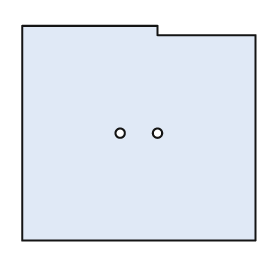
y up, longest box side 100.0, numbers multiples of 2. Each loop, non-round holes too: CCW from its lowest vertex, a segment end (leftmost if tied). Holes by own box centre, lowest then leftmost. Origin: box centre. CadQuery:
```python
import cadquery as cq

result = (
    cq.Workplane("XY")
    .moveTo(-50.0, -46.0)
    .lineTo(50.0, -46.0)
    .lineTo(50.0, 42.0)
    .lineTo(8.0, 42.0)
    .lineTo(8.0, 46.0)
    .lineTo(-50.0, 46.0)
    .close()
    .moveTo(-8.0, 0.0)
    .circle(2.0)
    .moveTo(8.0, 0.0)
    .circle(2.0)
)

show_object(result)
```